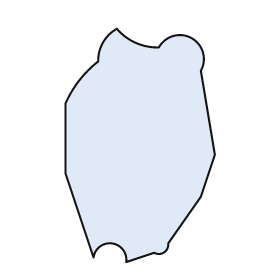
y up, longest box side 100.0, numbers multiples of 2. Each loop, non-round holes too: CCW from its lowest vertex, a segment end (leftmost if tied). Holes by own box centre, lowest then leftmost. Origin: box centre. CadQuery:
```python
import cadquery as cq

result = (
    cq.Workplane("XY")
    .moveTo(-6.0, -50.0)
    .lineTo(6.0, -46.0)
    .threePointArc((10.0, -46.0), (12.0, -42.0))
    .lineTo(26.0, -22.0)
    .lineTo(32.0, -4.0)
    .lineTo(26.0, 32.0)
    .threePointArc((22.0, 46.0), (8.0, 42.0))
    .threePointArc((-2.0, 44.0), (-10.0, 50.0))
    .threePointArc((-16.0, 44.0), (-18.0, 36.0))
    .threePointArc((-26.0, 28.0), (-32.0, 18.0))
    .lineTo(-32.0, -12.0)
    .lineTo(-20.0, -48.0)
    .threePointArc((-12.0, -42.0), (-6.0, -50.0))
    .close()
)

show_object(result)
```